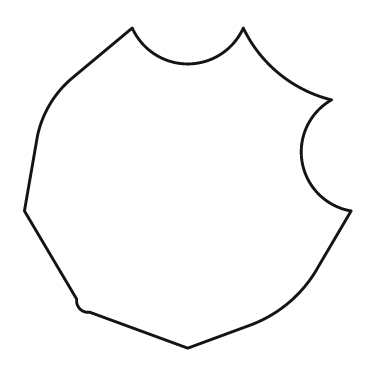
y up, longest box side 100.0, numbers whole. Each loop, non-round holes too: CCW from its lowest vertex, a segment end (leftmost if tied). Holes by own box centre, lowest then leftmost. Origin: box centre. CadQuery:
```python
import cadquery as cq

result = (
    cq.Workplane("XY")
    .moveTo(0.0, -49.0)
    .lineTo(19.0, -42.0)
    .threePointArc((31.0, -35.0), (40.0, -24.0))
    .lineTo(50.0, -7.0)
    .threePointArc((35.0, 8.0), (44.0, 27.0))
    .threePointArc((28.0, 35.0), (17.0, 49.0))
    .threePointArc((0.0, 38.0), (-17.0, 49.0))
    .lineTo(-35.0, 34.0)
    .threePointArc((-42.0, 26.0), (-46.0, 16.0))
    .lineTo(-50.0, -7.0)
    .lineTo(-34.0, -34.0)
    .threePointArc((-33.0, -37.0), (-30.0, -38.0))
    .close()
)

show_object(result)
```